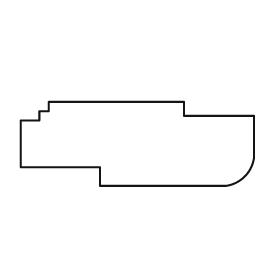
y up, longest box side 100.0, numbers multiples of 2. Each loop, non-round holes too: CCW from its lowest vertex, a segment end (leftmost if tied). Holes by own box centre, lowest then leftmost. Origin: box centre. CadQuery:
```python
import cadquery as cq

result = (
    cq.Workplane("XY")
    .moveTo(-16.0, -18.0)
    .lineTo(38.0, -18.0)
    .threePointArc((46.0, -14.0), (50.0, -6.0))
    .lineTo(50.0, 12.0)
    .lineTo(20.0, 12.0)
    .lineTo(20.0, 18.0)
    .lineTo(-38.0, 18.0)
    .lineTo(-38.0, 14.0)
    .lineTo(-42.0, 14.0)
    .lineTo(-42.0, 10.0)
    .lineTo(-50.0, 10.0)
    .lineTo(-50.0, -10.0)
    .lineTo(-16.0, -10.0)
    .close()
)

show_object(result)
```